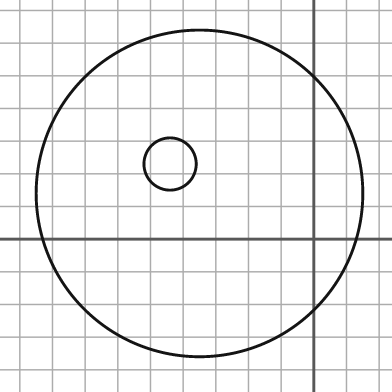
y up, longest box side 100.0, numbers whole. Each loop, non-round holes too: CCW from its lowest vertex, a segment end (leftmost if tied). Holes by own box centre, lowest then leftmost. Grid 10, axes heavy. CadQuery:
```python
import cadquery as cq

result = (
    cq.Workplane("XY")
    .moveTo(-35.0, 14.0)
    .circle(50.0)
    .moveTo(-44.0, 23.0)
    .circle(8.0)
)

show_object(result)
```